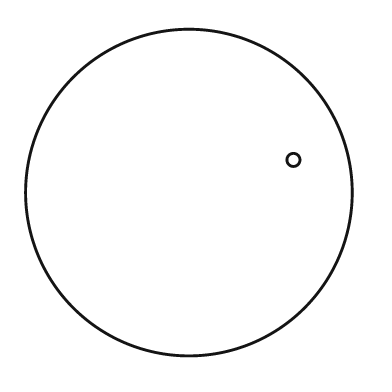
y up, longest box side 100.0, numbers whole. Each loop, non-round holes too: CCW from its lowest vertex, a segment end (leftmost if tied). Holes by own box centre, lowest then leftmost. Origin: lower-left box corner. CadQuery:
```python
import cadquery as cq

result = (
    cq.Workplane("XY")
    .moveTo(50.0, 50.0)
    .circle(50.0)
    .moveTo(82.0, 60.0)
    .circle(2.0)
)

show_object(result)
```